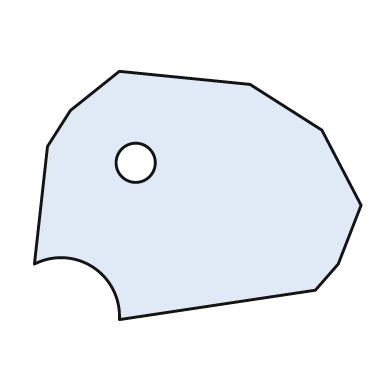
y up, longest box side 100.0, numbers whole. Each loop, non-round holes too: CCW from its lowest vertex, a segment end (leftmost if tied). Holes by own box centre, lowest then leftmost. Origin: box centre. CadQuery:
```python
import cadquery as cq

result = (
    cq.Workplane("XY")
    .moveTo(-24.0, -38.0)
    .lineTo(36.0, -29.0)
    .lineTo(43.0, -21.0)
    .lineTo(50.0, -3.0)
    .lineTo(38.0, 20.0)
    .lineTo(16.0, 34.0)
    .lineTo(-24.0, 38.0)
    .lineTo(-39.0, 26.0)
    .lineTo(-46.0, 15.0)
    .lineTo(-50.0, -21.0)
    .threePointArc((-32.0, -22.0), (-24.0, -38.0))
    .close()
    .moveTo(-19.0, 10.0)
    .circle(6.0)
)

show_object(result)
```